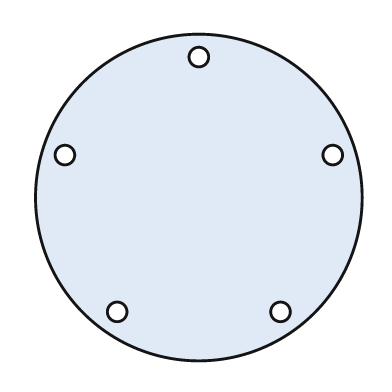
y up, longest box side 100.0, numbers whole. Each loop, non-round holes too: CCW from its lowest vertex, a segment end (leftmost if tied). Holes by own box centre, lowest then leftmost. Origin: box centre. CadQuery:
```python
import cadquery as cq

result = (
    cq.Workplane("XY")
    .moveTo(0.0, 0.0)
    .circle(50.0)
    .moveTo(-25.0, -35.0)
    .circle(3.0)
    .moveTo(25.0, -35.0)
    .circle(3.0)
    .moveTo(-41.0, 13.0)
    .circle(3.0)
    .moveTo(41.0, 13.0)
    .circle(3.0)
    .moveTo(0.0, 43.0)
    .circle(3.0)
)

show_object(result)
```